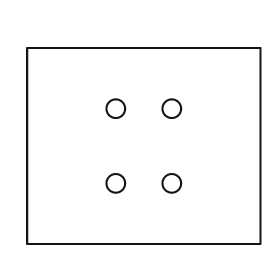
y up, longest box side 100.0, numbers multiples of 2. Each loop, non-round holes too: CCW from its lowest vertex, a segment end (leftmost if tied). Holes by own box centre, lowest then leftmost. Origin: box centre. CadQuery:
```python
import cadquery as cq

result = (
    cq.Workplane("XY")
    .moveTo(-50.0, -42.0)
    .lineTo(50.0, -42.0)
    .lineTo(50.0, 42.0)
    .lineTo(-50.0, 42.0)
    .close()
    .moveTo(-12.0, -16.0)
    .circle(4.0)
    .moveTo(12.0, -16.0)
    .circle(4.0)
    .moveTo(-12.0, 16.0)
    .circle(4.0)
    .moveTo(12.0, 16.0)
    .circle(4.0)
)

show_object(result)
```